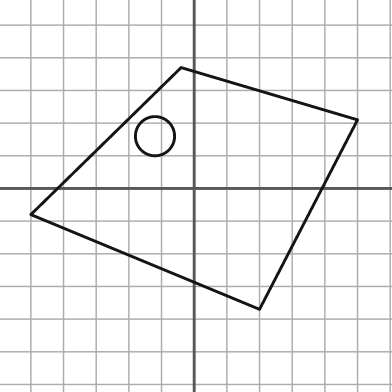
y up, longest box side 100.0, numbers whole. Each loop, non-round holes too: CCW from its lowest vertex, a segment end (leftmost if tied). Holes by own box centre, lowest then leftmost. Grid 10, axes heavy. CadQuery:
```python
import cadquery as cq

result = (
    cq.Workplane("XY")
    .moveTo(20.0, -37.0)
    .lineTo(50.0, 21.0)
    .lineTo(-4.0, 37.0)
    .lineTo(-50.0, -8.0)
    .close()
    .moveTo(-12.0, 16.0)
    .circle(6.0)
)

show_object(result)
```